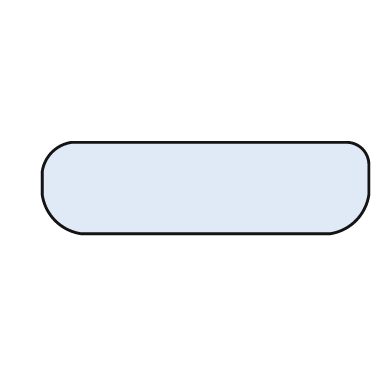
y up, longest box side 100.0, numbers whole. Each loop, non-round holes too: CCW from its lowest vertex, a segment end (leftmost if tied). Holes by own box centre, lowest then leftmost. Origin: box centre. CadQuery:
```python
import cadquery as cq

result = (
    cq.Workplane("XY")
    .moveTo(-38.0, -14.0)
    .lineTo(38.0, -14.0)
    .threePointArc((46.0, -10.0), (50.0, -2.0))
    .lineTo(50.0, 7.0)
    .threePointArc((48.0, 12.0), (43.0, 14.0))
    .lineTo(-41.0, 14.0)
    .threePointArc((-47.0, 11.0), (-50.0, 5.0))
    .lineTo(-50.0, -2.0)
    .threePointArc((-46.0, -10.0), (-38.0, -14.0))
    .close()
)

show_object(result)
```